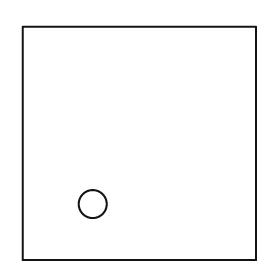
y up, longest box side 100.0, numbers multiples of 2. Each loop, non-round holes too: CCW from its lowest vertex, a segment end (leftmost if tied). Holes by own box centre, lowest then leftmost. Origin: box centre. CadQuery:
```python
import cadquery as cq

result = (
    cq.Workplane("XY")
    .moveTo(-50.0, -50.0)
    .lineTo(50.0, -50.0)
    .lineTo(50.0, 50.0)
    .lineTo(-50.0, 50.0)
    .close()
    .moveTo(-20.0, -26.0)
    .circle(6.0)
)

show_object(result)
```